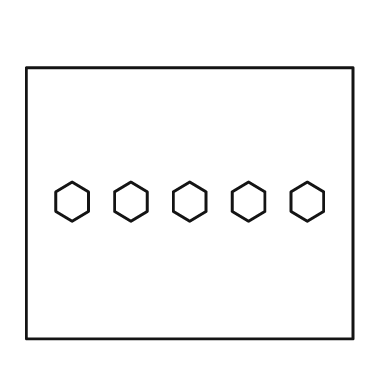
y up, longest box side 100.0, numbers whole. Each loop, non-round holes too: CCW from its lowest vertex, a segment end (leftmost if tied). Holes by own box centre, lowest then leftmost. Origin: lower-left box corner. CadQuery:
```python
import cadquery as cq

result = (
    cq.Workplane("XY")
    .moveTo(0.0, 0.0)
    .lineTo(100.0, 0.0)
    .lineTo(100.0, 83.0)
    .lineTo(0.0, 83.0)
    .close()
    .moveTo(14.0, 36.0)
    .lineTo(19.0, 39.0)
    .lineTo(19.0, 45.0)
    .lineTo(14.0, 48.0)
    .lineTo(9.0, 45.0)
    .lineTo(9.0, 39.0)
    .close()
    .moveTo(32.0, 36.0)
    .lineTo(37.0, 39.0)
    .lineTo(37.0, 45.0)
    .lineTo(32.0, 48.0)
    .lineTo(27.0, 45.0)
    .lineTo(27.0, 39.0)
    .close()
    .moveTo(50.0, 36.0)
    .lineTo(55.0, 39.0)
    .lineTo(55.0, 45.0)
    .lineTo(50.0, 48.0)
    .lineTo(45.0, 45.0)
    .lineTo(45.0, 39.0)
    .close()
    .moveTo(68.0, 36.0)
    .lineTo(73.0, 39.0)
    .lineTo(73.0, 45.0)
    .lineTo(68.0, 48.0)
    .lineTo(63.0, 45.0)
    .lineTo(63.0, 39.0)
    .close()
    .moveTo(86.0, 36.0)
    .lineTo(91.0, 39.0)
    .lineTo(91.0, 45.0)
    .lineTo(86.0, 48.0)
    .lineTo(81.0, 45.0)
    .lineTo(81.0, 39.0)
    .close()
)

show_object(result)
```